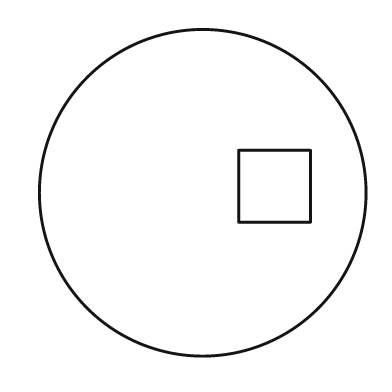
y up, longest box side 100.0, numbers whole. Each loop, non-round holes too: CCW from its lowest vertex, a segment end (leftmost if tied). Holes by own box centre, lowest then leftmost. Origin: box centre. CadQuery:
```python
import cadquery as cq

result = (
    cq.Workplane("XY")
    .moveTo(0.0, 0.0)
    .circle(50.0)
    .moveTo(11.0, -9.0)
    .lineTo(33.0, -9.0)
    .lineTo(33.0, 13.0)
    .lineTo(11.0, 13.0)
    .close()
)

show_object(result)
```